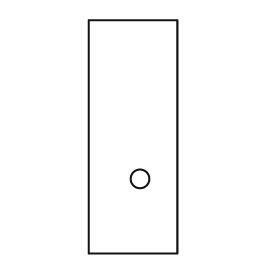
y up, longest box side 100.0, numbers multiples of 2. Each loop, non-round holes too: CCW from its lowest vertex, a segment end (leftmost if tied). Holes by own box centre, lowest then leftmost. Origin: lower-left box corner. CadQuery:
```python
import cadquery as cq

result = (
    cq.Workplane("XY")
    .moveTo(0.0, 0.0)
    .lineTo(38.0, 0.0)
    .lineTo(38.0, 100.0)
    .lineTo(0.0, 100.0)
    .close()
    .moveTo(22.0, 32.0)
    .circle(4.0)
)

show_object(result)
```